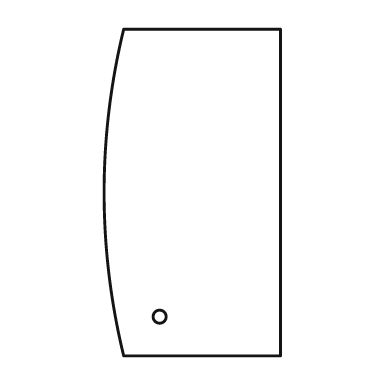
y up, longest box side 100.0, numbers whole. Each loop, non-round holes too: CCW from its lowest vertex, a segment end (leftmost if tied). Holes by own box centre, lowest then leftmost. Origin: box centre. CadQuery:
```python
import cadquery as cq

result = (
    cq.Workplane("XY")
    .moveTo(-21.0, -50.0)
    .lineTo(27.0, -50.0)
    .lineTo(27.0, 50.0)
    .lineTo(-21.0, 50.0)
    .threePointArc((-27.0, 0.0), (-21.0, -50.0))
    .close()
    .moveTo(-10.0, -38.0)
    .circle(2.0)
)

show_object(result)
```